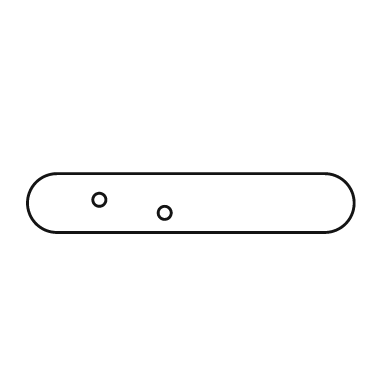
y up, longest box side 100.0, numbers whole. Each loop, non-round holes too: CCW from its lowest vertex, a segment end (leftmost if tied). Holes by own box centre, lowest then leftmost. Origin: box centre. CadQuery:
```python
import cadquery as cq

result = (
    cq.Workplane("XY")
    .moveTo(-41.0, -9.0)
    .lineTo(41.0, -9.0)
    .threePointArc((50.0, 0.0), (41.0, 9.0))
    .lineTo(-41.0, 9.0)
    .threePointArc((-50.0, 0.0), (-41.0, -9.0))
    .close()
    .moveTo(-8.0, -3.0)
    .circle(2.0)
    .moveTo(-28.0, 1.0)
    .circle(2.0)
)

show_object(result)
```